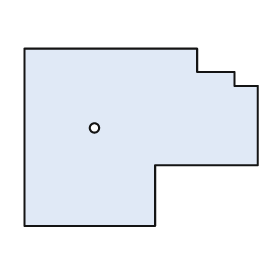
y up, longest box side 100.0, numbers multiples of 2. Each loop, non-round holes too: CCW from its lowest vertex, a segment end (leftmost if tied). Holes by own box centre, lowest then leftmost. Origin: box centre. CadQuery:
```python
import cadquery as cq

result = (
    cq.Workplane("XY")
    .moveTo(-50.0, -38.0)
    .lineTo(6.0, -38.0)
    .lineTo(6.0, -12.0)
    .lineTo(50.0, -12.0)
    .lineTo(50.0, 22.0)
    .lineTo(40.0, 22.0)
    .lineTo(40.0, 28.0)
    .lineTo(24.0, 28.0)
    .lineTo(24.0, 38.0)
    .lineTo(-50.0, 38.0)
    .close()
    .moveTo(-20.0, 4.0)
    .circle(2.0)
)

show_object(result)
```